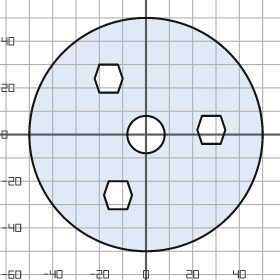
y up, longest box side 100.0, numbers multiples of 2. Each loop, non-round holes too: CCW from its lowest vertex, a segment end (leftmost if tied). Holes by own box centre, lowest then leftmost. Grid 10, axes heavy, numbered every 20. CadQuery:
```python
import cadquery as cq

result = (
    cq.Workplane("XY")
    .moveTo(0.0, 0.0)
    .circle(50.0)
    .moveTo(-16.0, -32.0)
    .lineTo(-8.0, -32.0)
    .lineTo(-6.0, -26.0)
    .lineTo(-8.0, -20.0)
    .lineTo(-16.0, -20.0)
    .lineTo(-18.0, -26.0)
    .close()
    .moveTo(0.0, 0.0)
    .circle(8.0)
    .moveTo(24.0, -4.0)
    .lineTo(32.0, -4.0)
    .lineTo(34.0, 2.0)
    .lineTo(32.0, 8.0)
    .lineTo(24.0, 8.0)
    .lineTo(22.0, 2.0)
    .close()
    .moveTo(-20.0, 18.0)
    .lineTo(-12.0, 18.0)
    .lineTo(-10.0, 24.0)
    .lineTo(-12.0, 30.0)
    .lineTo(-20.0, 30.0)
    .lineTo(-22.0, 24.0)
    .close()
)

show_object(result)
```